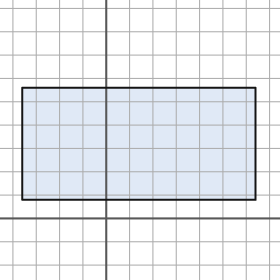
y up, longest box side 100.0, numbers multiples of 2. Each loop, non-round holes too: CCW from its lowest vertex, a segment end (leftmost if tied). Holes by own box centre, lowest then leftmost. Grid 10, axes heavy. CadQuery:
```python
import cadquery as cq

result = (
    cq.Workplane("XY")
    .moveTo(-36.0, 8.0)
    .lineTo(64.0, 8.0)
    .lineTo(64.0, 56.0)
    .lineTo(-36.0, 56.0)
    .close()
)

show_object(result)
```